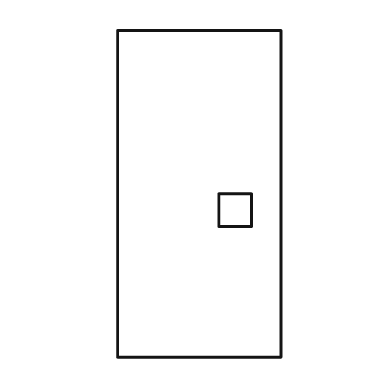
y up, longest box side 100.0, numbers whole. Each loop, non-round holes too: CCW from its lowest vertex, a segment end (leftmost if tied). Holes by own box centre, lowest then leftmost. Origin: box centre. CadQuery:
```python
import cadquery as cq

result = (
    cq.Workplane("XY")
    .moveTo(-25.0, -50.0)
    .lineTo(25.0, -50.0)
    .lineTo(25.0, 50.0)
    .lineTo(-25.0, 50.0)
    .close()
    .moveTo(6.0, -10.0)
    .lineTo(16.0, -10.0)
    .lineTo(16.0, 0.0)
    .lineTo(6.0, 0.0)
    .close()
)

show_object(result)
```